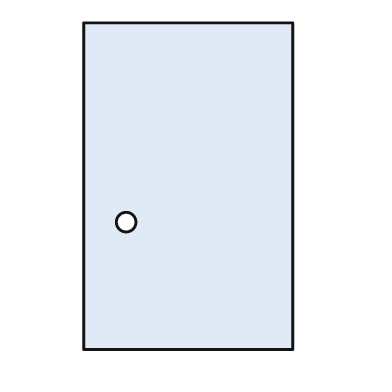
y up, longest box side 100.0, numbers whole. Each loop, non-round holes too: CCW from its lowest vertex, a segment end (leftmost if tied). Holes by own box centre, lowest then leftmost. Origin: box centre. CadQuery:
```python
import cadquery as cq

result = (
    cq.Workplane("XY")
    .moveTo(-32.0, -50.0)
    .lineTo(32.0, -50.0)
    .lineTo(32.0, 50.0)
    .lineTo(-32.0, 50.0)
    .close()
    .moveTo(-19.0, -11.0)
    .circle(3.0)
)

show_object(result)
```